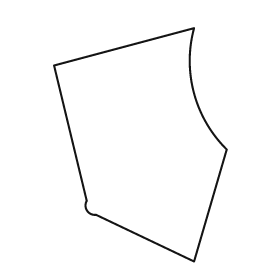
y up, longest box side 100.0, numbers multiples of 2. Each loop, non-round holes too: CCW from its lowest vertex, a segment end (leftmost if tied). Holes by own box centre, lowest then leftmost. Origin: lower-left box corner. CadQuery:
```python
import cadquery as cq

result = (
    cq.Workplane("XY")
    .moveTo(60.0, 0.0)
    .lineTo(74.0, 48.0)
    .threePointArc((60.0, 72.0), (60.0, 100.0))
    .lineTo(0.0, 84.0)
    .lineTo(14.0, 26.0)
    .threePointArc((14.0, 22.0), (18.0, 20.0))
    .close()
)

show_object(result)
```